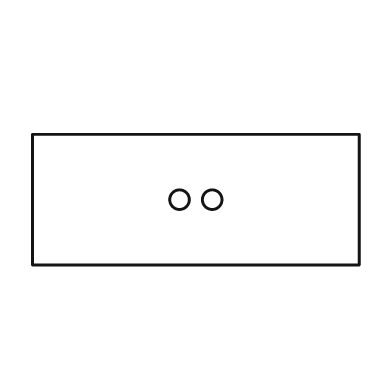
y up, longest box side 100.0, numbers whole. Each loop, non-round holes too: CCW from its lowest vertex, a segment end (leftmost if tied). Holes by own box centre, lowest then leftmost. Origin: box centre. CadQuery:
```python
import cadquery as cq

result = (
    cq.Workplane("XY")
    .moveTo(-50.0, -20.0)
    .lineTo(50.0, -20.0)
    .lineTo(50.0, 20.0)
    .lineTo(-50.0, 20.0)
    .close()
    .moveTo(-5.0, 0.0)
    .circle(3.0)
    .moveTo(5.0, 0.0)
    .circle(3.0)
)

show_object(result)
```